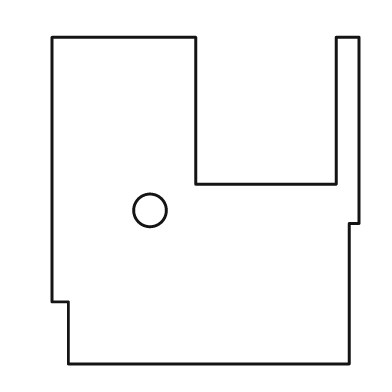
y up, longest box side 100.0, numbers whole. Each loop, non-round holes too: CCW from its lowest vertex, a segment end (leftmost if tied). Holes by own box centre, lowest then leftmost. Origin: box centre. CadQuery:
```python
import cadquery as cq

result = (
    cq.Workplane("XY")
    .moveTo(-42.0, -50.0)
    .lineTo(44.0, -50.0)
    .lineTo(44.0, -7.0)
    .lineTo(47.0, -7.0)
    .lineTo(47.0, 50.0)
    .lineTo(40.0, 50.0)
    .lineTo(40.0, 5.0)
    .lineTo(-3.0, 5.0)
    .lineTo(-3.0, 50.0)
    .lineTo(-47.0, 50.0)
    .lineTo(-47.0, -31.0)
    .lineTo(-42.0, -31.0)
    .close()
    .moveTo(-17.0, -3.0)
    .circle(5.0)
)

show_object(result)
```